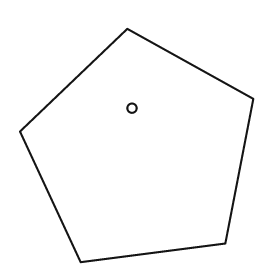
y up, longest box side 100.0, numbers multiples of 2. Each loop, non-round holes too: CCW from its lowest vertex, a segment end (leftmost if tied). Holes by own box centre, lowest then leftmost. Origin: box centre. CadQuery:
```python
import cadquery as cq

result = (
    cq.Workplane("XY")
    .moveTo(-24.0, -50.0)
    .lineTo(38.0, -42.0)
    .lineTo(50.0, 20.0)
    .lineTo(-4.0, 50.0)
    .lineTo(-50.0, 6.0)
    .close()
    .moveTo(-2.0, 16.0)
    .circle(2.0)
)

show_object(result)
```